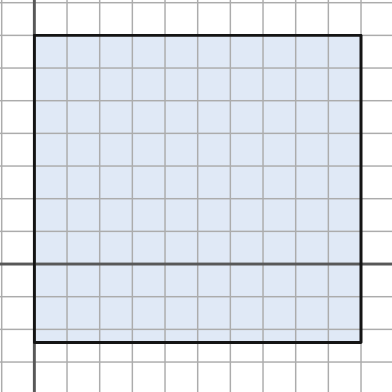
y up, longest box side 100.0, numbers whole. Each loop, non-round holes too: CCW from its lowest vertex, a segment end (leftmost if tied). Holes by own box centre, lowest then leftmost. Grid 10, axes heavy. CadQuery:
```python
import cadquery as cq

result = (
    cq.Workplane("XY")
    .moveTo(0.0, -24.0)
    .lineTo(100.0, -24.0)
    .lineTo(100.0, 70.0)
    .lineTo(0.0, 70.0)
    .close()
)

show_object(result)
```